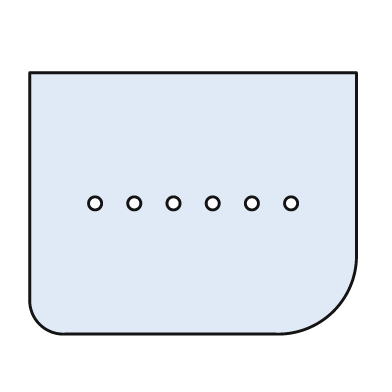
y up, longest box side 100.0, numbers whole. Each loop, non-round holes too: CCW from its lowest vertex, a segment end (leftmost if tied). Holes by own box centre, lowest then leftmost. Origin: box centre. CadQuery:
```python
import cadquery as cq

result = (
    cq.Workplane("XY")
    .moveTo(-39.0, -40.0)
    .lineTo(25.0, -40.0)
    .threePointArc((43.0, -33.0), (50.0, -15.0))
    .lineTo(50.0, 40.0)
    .lineTo(-50.0, 40.0)
    .lineTo(-50.0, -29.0)
    .threePointArc((-47.0, -37.0), (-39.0, -40.0))
    .close()
    .moveTo(-30.0, 0.0)
    .circle(2.0)
    .moveTo(-18.0, 0.0)
    .circle(2.0)
    .moveTo(-6.0, 0.0)
    .circle(2.0)
    .moveTo(6.0, 0.0)
    .circle(2.0)
    .moveTo(18.0, 0.0)
    .circle(2.0)
    .moveTo(30.0, 0.0)
    .circle(2.0)
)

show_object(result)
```